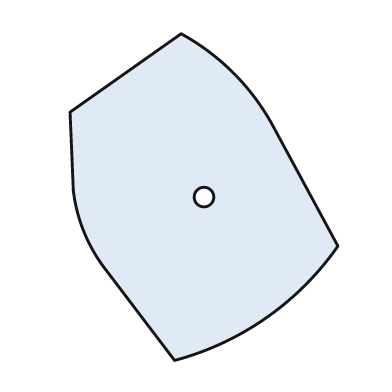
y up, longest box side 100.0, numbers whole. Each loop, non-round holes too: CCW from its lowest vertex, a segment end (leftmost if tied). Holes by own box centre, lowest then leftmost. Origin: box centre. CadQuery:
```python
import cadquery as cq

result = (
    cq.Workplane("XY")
    .moveTo(-9.0, -50.0)
    .threePointArc((19.0, -37.0), (41.0, -15.0))
    .lineTo(21.0, 22.0)
    .threePointArc((9.0, 38.0), (-7.0, 50.0))
    .lineTo(-41.0, 26.0)
    .lineTo(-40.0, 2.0)
    .threePointArc((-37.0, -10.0), (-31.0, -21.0))
    .close()
    .moveTo(0.0, 0.0)
    .circle(3.0)
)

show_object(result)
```